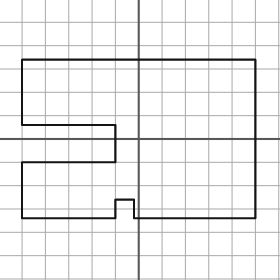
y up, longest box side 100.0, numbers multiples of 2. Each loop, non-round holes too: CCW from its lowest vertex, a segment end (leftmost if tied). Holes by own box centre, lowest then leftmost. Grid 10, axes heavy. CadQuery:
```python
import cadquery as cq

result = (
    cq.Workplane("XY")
    .moveTo(-50.0, -34.0)
    .lineTo(-10.0, -34.0)
    .lineTo(-10.0, -26.0)
    .lineTo(-2.0, -26.0)
    .lineTo(-2.0, -34.0)
    .lineTo(50.0, -34.0)
    .lineTo(50.0, 34.0)
    .lineTo(-50.0, 34.0)
    .lineTo(-50.0, 6.0)
    .lineTo(-10.0, 6.0)
    .lineTo(-10.0, -10.0)
    .lineTo(-50.0, -10.0)
    .close()
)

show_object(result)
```